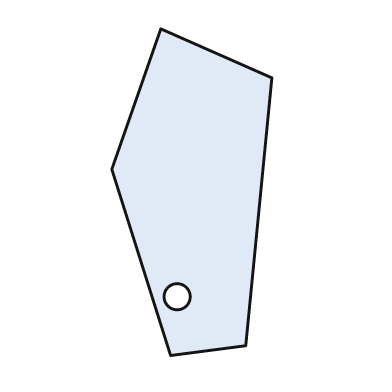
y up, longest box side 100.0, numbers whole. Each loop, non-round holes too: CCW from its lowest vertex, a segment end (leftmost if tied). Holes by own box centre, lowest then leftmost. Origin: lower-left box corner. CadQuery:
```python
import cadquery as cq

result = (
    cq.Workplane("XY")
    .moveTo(18.0, 0.0)
    .lineTo(41.0, 3.0)
    .lineTo(49.0, 85.0)
    .lineTo(15.0, 100.0)
    .lineTo(0.0, 57.0)
    .close()
    .moveTo(20.0, 18.0)
    .circle(4.0)
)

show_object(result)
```